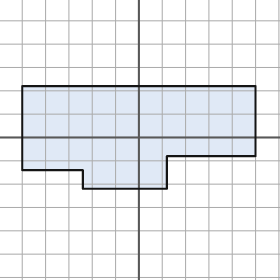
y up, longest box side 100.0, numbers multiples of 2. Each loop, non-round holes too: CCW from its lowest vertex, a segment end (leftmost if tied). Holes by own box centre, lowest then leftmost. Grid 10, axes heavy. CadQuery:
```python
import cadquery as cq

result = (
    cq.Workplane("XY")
    .moveTo(-24.0, -22.0)
    .lineTo(12.0, -22.0)
    .lineTo(12.0, -8.0)
    .lineTo(50.0, -8.0)
    .lineTo(50.0, 22.0)
    .lineTo(-50.0, 22.0)
    .lineTo(-50.0, -14.0)
    .lineTo(-24.0, -14.0)
    .close()
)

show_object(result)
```